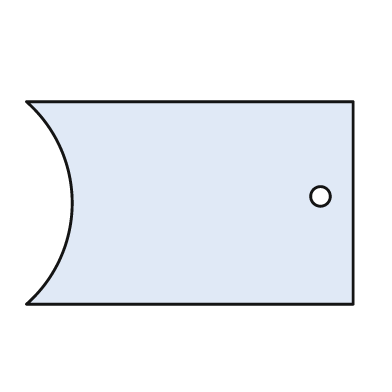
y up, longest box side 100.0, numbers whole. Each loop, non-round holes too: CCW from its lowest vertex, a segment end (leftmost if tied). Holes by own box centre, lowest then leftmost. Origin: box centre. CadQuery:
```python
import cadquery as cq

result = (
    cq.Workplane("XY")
    .moveTo(-50.0, -31.0)
    .lineTo(50.0, -31.0)
    .lineTo(50.0, 31.0)
    .lineTo(-50.0, 31.0)
    .threePointArc((-36.0, 0.0), (-50.0, -31.0))
    .close()
    .moveTo(40.0, 2.0)
    .circle(3.0)
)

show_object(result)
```